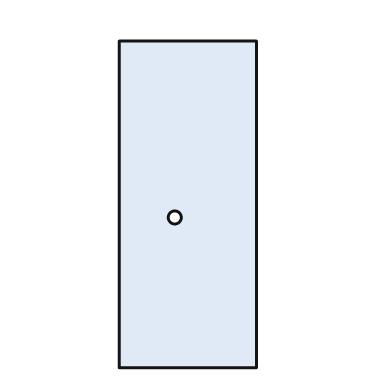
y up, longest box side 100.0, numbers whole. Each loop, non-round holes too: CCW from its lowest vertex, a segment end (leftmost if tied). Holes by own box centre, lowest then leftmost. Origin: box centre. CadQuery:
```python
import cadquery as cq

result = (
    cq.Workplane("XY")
    .moveTo(-21.0, -50.0)
    .lineTo(21.0, -50.0)
    .lineTo(21.0, 50.0)
    .lineTo(-21.0, 50.0)
    .close()
    .moveTo(-4.0, -4.0)
    .circle(2.0)
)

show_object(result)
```